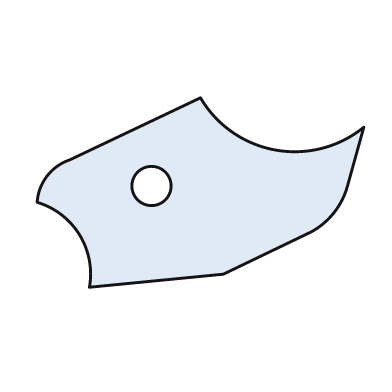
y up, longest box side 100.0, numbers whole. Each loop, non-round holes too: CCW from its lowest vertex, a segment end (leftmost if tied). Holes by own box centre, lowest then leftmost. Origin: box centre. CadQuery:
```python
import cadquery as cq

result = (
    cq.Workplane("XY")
    .moveTo(-34.0, -29.0)
    .lineTo(7.0, -25.0)
    .lineTo(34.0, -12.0)
    .threePointArc((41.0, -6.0), (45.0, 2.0))
    .lineTo(50.0, 20.0)
    .threePointArc((23.0, 13.0), (0.0, 29.0))
    .lineTo(-40.0, 10.0)
    .threePointArc((-47.0, 5.0), (-50.0, -3.0))
    .threePointArc((-37.0, -13.0), (-34.0, -29.0))
    .close()
    .moveTo(-15.0, 2.0)
    .circle(6.0)
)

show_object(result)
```